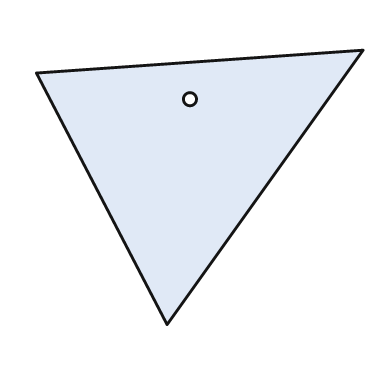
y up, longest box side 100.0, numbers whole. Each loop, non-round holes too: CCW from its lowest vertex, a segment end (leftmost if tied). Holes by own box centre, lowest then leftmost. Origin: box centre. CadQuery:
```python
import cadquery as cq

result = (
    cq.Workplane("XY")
    .moveTo(-10.0, -42.0)
    .lineTo(50.0, 42.0)
    .lineTo(-50.0, 35.0)
    .close()
    .moveTo(-3.0, 27.0)
    .circle(2.0)
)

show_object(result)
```